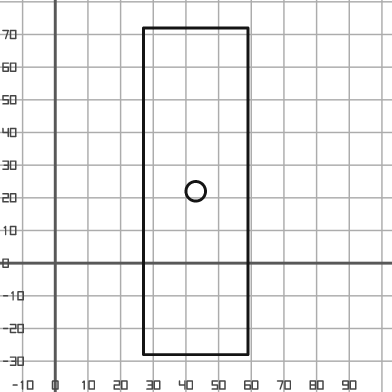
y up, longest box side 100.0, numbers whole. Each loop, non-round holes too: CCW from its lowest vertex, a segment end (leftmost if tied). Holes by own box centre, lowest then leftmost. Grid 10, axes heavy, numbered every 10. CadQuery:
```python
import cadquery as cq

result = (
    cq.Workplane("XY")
    .moveTo(27.0, -28.0)
    .lineTo(59.0, -28.0)
    .lineTo(59.0, 72.0)
    .lineTo(27.0, 72.0)
    .close()
    .moveTo(43.0, 22.0)
    .circle(3.0)
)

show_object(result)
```